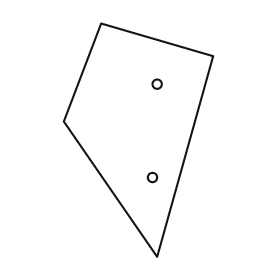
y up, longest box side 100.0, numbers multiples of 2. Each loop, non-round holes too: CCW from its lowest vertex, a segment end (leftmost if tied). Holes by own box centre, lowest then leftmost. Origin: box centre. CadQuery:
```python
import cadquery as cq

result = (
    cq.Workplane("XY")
    .moveTo(8.0, -50.0)
    .lineTo(32.0, 36.0)
    .lineTo(-16.0, 50.0)
    .lineTo(-32.0, 8.0)
    .close()
    .moveTo(6.0, -16.0)
    .circle(2.0)
    .moveTo(8.0, 24.0)
    .circle(2.0)
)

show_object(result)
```